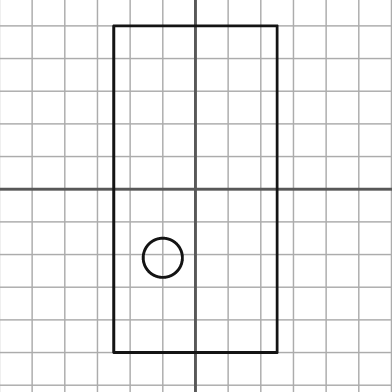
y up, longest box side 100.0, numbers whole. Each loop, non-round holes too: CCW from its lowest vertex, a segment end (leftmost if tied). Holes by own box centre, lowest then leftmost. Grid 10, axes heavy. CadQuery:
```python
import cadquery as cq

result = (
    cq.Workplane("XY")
    .moveTo(-25.0, -50.0)
    .lineTo(25.0, -50.0)
    .lineTo(25.0, 50.0)
    .lineTo(-25.0, 50.0)
    .close()
    .moveTo(-10.0, -21.0)
    .circle(6.0)
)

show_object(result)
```